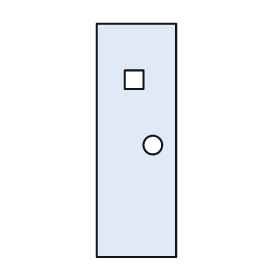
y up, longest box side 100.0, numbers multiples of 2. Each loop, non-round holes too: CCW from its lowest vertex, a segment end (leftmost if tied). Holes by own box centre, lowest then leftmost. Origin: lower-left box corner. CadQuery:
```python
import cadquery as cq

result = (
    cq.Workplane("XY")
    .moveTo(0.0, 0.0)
    .lineTo(34.0, 0.0)
    .lineTo(34.0, 100.0)
    .lineTo(0.0, 100.0)
    .close()
    .moveTo(24.0, 48.0)
    .circle(4.0)
    .moveTo(12.0, 72.0)
    .lineTo(20.0, 72.0)
    .lineTo(20.0, 80.0)
    .lineTo(12.0, 80.0)
    .close()
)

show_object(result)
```